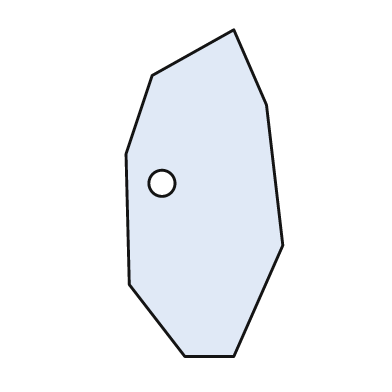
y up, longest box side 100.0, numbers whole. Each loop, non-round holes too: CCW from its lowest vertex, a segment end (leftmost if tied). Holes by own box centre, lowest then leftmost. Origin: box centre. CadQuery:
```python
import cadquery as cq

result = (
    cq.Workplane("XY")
    .moveTo(-6.0, -50.0)
    .lineTo(9.0, -50.0)
    .lineTo(24.0, -16.0)
    .lineTo(19.0, 27.0)
    .lineTo(9.0, 50.0)
    .lineTo(-16.0, 36.0)
    .lineTo(-24.0, 12.0)
    .lineTo(-23.0, -28.0)
    .close()
    .moveTo(-13.0, 3.0)
    .circle(4.0)
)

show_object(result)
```